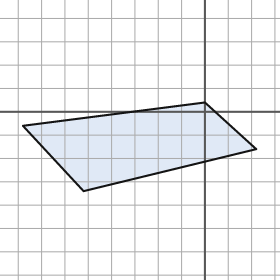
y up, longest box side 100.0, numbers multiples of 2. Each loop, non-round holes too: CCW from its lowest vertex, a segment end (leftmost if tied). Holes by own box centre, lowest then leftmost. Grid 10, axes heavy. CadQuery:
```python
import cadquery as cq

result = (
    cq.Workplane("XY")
    .moveTo(-52.0, -34.0)
    .lineTo(22.0, -16.0)
    .lineTo(0.0, 4.0)
    .lineTo(-78.0, -6.0)
    .close()
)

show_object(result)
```